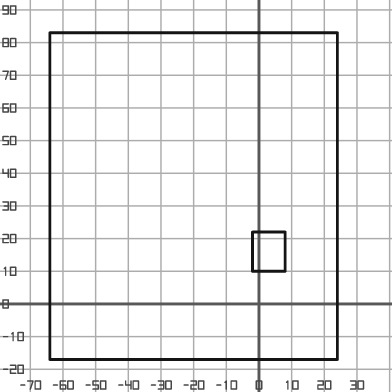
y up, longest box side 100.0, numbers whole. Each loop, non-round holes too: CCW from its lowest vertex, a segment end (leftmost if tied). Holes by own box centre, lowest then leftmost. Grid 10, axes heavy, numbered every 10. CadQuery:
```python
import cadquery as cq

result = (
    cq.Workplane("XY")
    .moveTo(-64.0, -17.0)
    .lineTo(24.0, -17.0)
    .lineTo(24.0, 83.0)
    .lineTo(-64.0, 83.0)
    .close()
    .moveTo(-2.0, 10.0)
    .lineTo(8.0, 10.0)
    .lineTo(8.0, 22.0)
    .lineTo(-2.0, 22.0)
    .close()
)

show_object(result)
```